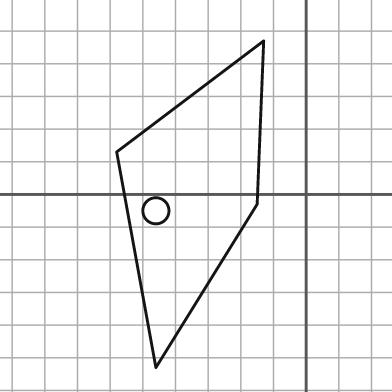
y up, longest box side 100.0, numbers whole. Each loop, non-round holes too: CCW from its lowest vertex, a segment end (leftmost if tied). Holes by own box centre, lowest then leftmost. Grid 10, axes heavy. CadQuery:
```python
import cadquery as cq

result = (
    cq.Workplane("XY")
    .moveTo(-46.0, -53.0)
    .lineTo(-15.0, -3.0)
    .lineTo(-13.0, 47.0)
    .lineTo(-58.0, 13.0)
    .close()
    .moveTo(-46.0, -5.0)
    .circle(4.0)
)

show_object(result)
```